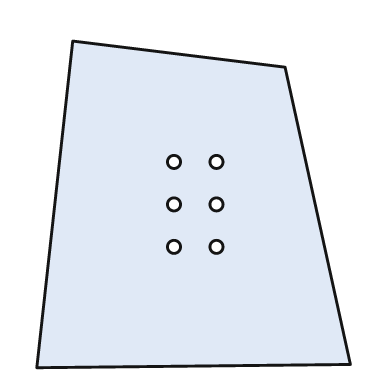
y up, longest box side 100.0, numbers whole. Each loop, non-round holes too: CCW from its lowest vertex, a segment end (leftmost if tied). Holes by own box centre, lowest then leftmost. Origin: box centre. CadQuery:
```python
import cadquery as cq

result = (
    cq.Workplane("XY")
    .moveTo(-48.0, -50.0)
    .lineTo(48.0, -49.0)
    .lineTo(28.0, 42.0)
    .lineTo(-37.0, 50.0)
    .close()
    .moveTo(-6.0, -13.0)
    .circle(2.0)
    .moveTo(7.0, -13.0)
    .circle(2.0)
    .moveTo(-6.0, 0.0)
    .circle(2.0)
    .moveTo(7.0, 0.0)
    .circle(2.0)
    .moveTo(-6.0, 13.0)
    .circle(2.0)
    .moveTo(7.0, 13.0)
    .circle(2.0)
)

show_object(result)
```